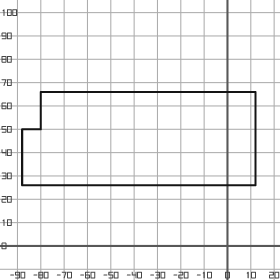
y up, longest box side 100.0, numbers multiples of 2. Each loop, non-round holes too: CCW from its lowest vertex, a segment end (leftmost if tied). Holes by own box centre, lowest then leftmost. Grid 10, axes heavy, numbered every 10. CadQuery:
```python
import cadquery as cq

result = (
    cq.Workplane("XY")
    .moveTo(-88.0, 26.0)
    .lineTo(12.0, 26.0)
    .lineTo(12.0, 66.0)
    .lineTo(-80.0, 66.0)
    .lineTo(-80.0, 50.0)
    .lineTo(-88.0, 50.0)
    .close()
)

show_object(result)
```